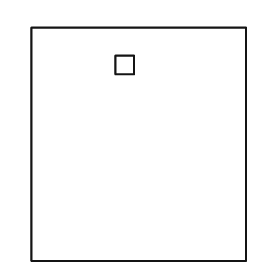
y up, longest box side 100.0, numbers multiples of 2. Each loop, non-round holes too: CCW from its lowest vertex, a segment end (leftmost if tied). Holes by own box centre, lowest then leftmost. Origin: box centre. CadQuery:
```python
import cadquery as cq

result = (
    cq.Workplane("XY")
    .moveTo(-46.0, -50.0)
    .lineTo(46.0, -50.0)
    .lineTo(46.0, 50.0)
    .lineTo(-46.0, 50.0)
    .close()
    .moveTo(-10.0, 30.0)
    .lineTo(-2.0, 30.0)
    .lineTo(-2.0, 38.0)
    .lineTo(-10.0, 38.0)
    .close()
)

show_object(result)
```